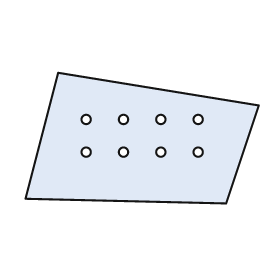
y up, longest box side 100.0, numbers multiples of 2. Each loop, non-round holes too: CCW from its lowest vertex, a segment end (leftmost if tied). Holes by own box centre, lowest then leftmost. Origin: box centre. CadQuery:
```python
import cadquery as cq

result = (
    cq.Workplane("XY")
    .moveTo(36.0, -28.0)
    .lineTo(50.0, 14.0)
    .lineTo(-36.0, 28.0)
    .lineTo(-50.0, -26.0)
    .close()
    .moveTo(-24.0, -6.0)
    .circle(2.0)
    .moveTo(-8.0, -6.0)
    .circle(2.0)
    .moveTo(8.0, -6.0)
    .circle(2.0)
    .moveTo(24.0, -6.0)
    .circle(2.0)
    .moveTo(-24.0, 8.0)
    .circle(2.0)
    .moveTo(-8.0, 8.0)
    .circle(2.0)
    .moveTo(8.0, 8.0)
    .circle(2.0)
    .moveTo(24.0, 8.0)
    .circle(2.0)
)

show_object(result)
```